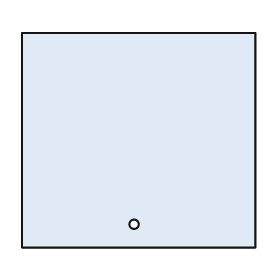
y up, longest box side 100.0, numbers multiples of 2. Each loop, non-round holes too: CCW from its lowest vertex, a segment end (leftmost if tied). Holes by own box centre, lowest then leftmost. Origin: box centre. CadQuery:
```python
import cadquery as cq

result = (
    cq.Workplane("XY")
    .moveTo(-50.0, -46.0)
    .lineTo(50.0, -46.0)
    .lineTo(50.0, 46.0)
    .lineTo(-50.0, 46.0)
    .close()
    .moveTo(-2.0, -36.0)
    .circle(2.0)
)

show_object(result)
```